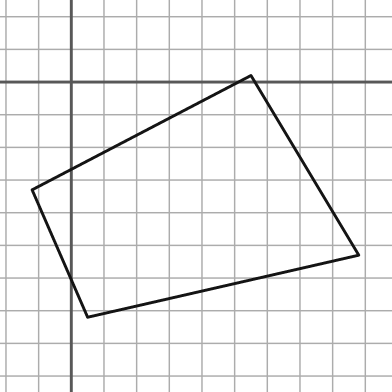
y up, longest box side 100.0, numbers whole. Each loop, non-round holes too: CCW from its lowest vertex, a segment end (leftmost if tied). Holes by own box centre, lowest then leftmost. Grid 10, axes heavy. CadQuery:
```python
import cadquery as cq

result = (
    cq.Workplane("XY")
    .moveTo(5.0, -72.0)
    .lineTo(88.0, -53.0)
    .lineTo(55.0, 2.0)
    .lineTo(-12.0, -33.0)
    .close()
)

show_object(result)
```